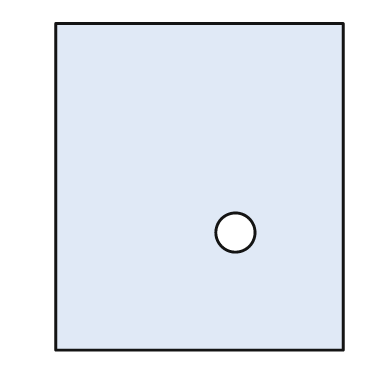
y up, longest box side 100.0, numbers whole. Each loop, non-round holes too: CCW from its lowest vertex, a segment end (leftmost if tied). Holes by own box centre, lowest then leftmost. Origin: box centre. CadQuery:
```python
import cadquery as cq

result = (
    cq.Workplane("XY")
    .moveTo(-44.0, -50.0)
    .lineTo(44.0, -50.0)
    .lineTo(44.0, 50.0)
    .lineTo(-44.0, 50.0)
    .close()
    .moveTo(11.0, -14.0)
    .circle(6.0)
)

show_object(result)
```